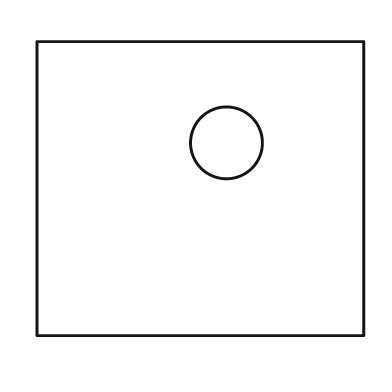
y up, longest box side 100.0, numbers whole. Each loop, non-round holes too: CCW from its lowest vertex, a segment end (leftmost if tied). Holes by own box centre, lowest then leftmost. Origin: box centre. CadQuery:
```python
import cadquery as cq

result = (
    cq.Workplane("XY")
    .moveTo(-50.0, -45.0)
    .lineTo(50.0, -45.0)
    .lineTo(50.0, 45.0)
    .lineTo(-50.0, 45.0)
    .close()
    .moveTo(8.0, 14.0)
    .circle(11.0)
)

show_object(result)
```